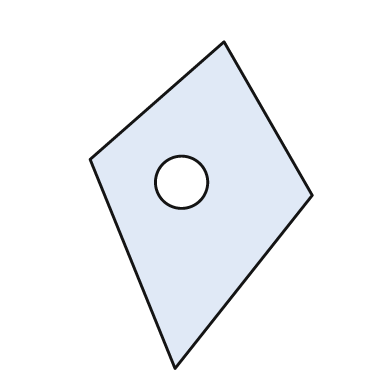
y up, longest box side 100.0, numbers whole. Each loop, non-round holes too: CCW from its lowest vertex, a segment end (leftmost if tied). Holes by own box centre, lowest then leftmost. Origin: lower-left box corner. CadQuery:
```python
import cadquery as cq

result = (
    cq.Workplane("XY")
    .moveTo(26.0, 0.0)
    .lineTo(68.0, 53.0)
    .lineTo(41.0, 100.0)
    .lineTo(0.0, 64.0)
    .close()
    .moveTo(28.0, 57.0)
    .circle(8.0)
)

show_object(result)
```